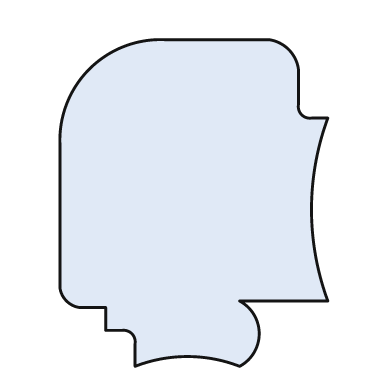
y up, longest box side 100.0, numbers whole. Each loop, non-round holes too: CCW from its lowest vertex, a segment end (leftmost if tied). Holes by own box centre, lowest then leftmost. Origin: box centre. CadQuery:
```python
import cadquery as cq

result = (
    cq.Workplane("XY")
    .moveTo(-18.0, -50.0)
    .threePointArc((-2.0, -47.0), (14.0, -50.0))
    .threePointArc((20.0, -40.0), (14.0, -30.0))
    .lineTo(41.0, -30.0)
    .threePointArc((36.0, -2.0), (41.0, 26.0))
    .lineTo(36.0, 26.0)
    .threePointArc((33.0, 27.0), (32.0, 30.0))
    .lineTo(32.0, 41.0)
    .threePointArc((29.0, 47.0), (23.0, 50.0))
    .lineTo(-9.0, 50.0)
    .threePointArc((-32.0, 41.0), (-41.0, 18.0))
    .lineTo(-41.0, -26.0)
    .threePointArc((-39.0, -30.0), (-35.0, -32.0))
    .lineTo(-27.0, -32.0)
    .lineTo(-27.0, -39.0)
    .lineTo(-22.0, -39.0)
    .threePointArc((-19.0, -40.0), (-18.0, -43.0))
    .close()
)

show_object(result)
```